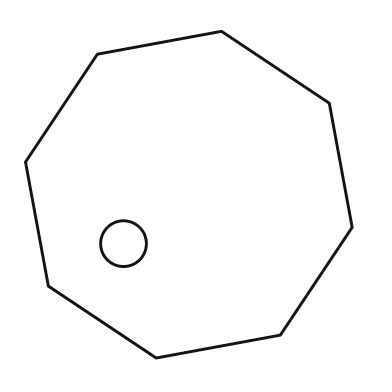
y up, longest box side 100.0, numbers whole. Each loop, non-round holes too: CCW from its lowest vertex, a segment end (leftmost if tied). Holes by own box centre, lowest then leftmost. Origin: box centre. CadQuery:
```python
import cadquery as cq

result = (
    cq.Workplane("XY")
    .moveTo(-10.0, -50.0)
    .lineTo(28.0, -43.0)
    .lineTo(50.0, -10.0)
    .lineTo(43.0, 28.0)
    .lineTo(10.0, 50.0)
    .lineTo(-28.0, 43.0)
    .lineTo(-50.0, 10.0)
    .lineTo(-43.0, -28.0)
    .close()
    .moveTo(-20.0, -15.0)
    .circle(7.0)
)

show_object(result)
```